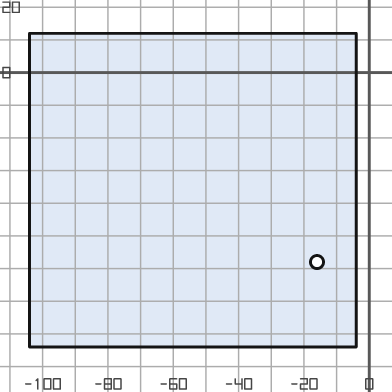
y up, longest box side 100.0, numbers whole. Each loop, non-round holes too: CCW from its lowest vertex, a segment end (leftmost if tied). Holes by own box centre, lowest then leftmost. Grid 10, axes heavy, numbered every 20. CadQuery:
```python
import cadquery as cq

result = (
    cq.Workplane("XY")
    .moveTo(-104.0, -84.0)
    .lineTo(-4.0, -84.0)
    .lineTo(-4.0, 12.0)
    .lineTo(-104.0, 12.0)
    .close()
    .moveTo(-16.0, -58.0)
    .circle(2.0)
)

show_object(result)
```